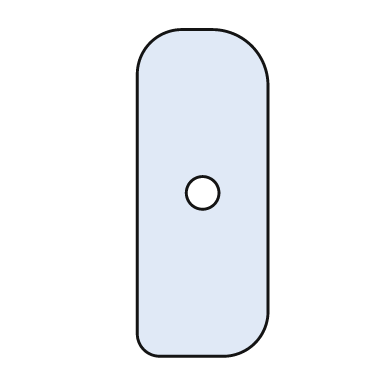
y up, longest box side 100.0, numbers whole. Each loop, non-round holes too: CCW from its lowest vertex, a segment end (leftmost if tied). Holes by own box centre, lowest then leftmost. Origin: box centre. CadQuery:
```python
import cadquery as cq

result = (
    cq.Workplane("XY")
    .moveTo(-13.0, -50.0)
    .lineTo(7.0, -50.0)
    .threePointArc((16.0, -46.0), (20.0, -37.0))
    .lineTo(20.0, 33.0)
    .threePointArc((15.0, 45.0), (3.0, 50.0))
    .lineTo(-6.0, 50.0)
    .threePointArc((-16.0, 46.0), (-20.0, 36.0))
    .lineTo(-20.0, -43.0)
    .threePointArc((-18.0, -48.0), (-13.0, -50.0))
    .close()
    .moveTo(0.0, 0.0)
    .circle(5.0)
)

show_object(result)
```